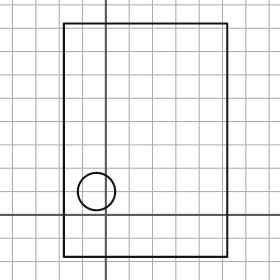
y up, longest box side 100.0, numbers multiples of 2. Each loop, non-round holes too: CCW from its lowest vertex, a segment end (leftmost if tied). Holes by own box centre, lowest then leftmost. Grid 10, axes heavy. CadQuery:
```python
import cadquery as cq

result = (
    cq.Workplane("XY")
    .moveTo(-18.0, -18.0)
    .lineTo(52.0, -18.0)
    .lineTo(52.0, 82.0)
    .lineTo(-18.0, 82.0)
    .close()
    .moveTo(-4.0, 10.0)
    .circle(8.0)
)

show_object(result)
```